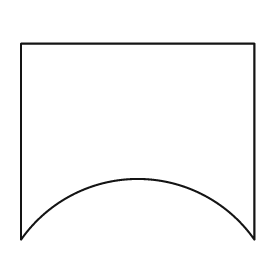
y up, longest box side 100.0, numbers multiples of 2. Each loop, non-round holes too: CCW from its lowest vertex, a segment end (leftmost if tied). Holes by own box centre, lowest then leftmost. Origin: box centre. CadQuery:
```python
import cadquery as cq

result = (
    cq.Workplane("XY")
    .moveTo(-50.0, -42.0)
    .threePointArc((0.0, -16.0), (50.0, -42.0))
    .lineTo(50.0, 42.0)
    .lineTo(-50.0, 42.0)
    .close()
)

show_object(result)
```